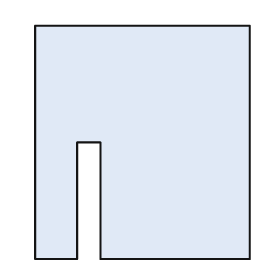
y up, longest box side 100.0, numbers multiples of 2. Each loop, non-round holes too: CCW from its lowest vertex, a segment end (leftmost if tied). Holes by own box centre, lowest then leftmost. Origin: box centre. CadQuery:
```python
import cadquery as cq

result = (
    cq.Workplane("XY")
    .moveTo(-46.0, -50.0)
    .lineTo(-28.0, -50.0)
    .lineTo(-28.0, 0.0)
    .lineTo(-18.0, 0.0)
    .lineTo(-18.0, -50.0)
    .lineTo(46.0, -50.0)
    .lineTo(46.0, 50.0)
    .lineTo(-46.0, 50.0)
    .close()
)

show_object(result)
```